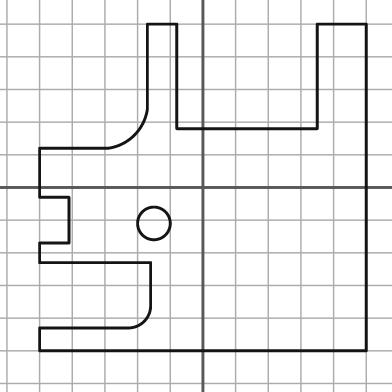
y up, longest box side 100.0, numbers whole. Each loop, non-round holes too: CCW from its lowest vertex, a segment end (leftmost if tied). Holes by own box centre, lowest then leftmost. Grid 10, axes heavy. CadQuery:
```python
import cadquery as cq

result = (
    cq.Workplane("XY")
    .moveTo(-50.0, -50.0)
    .lineTo(50.0, -50.0)
    .lineTo(50.0, 50.0)
    .lineTo(35.0, 50.0)
    .lineTo(35.0, 18.0)
    .lineTo(-8.0, 18.0)
    .lineTo(-8.0, 50.0)
    .lineTo(-17.0, 50.0)
    .lineTo(-17.0, 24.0)
    .threePointArc((-21.0, 16.0), (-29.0, 12.0))
    .lineTo(-50.0, 12.0)
    .lineTo(-50.0, -3.0)
    .lineTo(-41.0, -3.0)
    .lineTo(-41.0, -17.0)
    .lineTo(-50.0, -17.0)
    .lineTo(-50.0, -23.0)
    .lineTo(-16.0, -23.0)
    .lineTo(-16.0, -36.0)
    .threePointArc((-18.0, -41.0), (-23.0, -43.0))
    .lineTo(-50.0, -43.0)
    .close()
    .moveTo(-15.0, -11.0)
    .circle(5.0)
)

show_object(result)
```